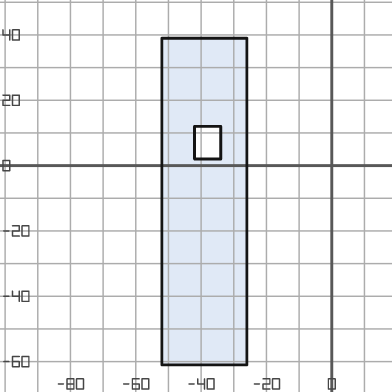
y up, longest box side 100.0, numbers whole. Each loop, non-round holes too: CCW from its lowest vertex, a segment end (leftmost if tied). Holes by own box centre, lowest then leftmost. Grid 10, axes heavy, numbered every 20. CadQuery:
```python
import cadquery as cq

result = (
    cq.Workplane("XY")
    .moveTo(-52.0, -61.0)
    .lineTo(-26.0, -61.0)
    .lineTo(-26.0, 39.0)
    .lineTo(-52.0, 39.0)
    .close()
    .moveTo(-42.0, 2.0)
    .lineTo(-34.0, 2.0)
    .lineTo(-34.0, 12.0)
    .lineTo(-42.0, 12.0)
    .close()
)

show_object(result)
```